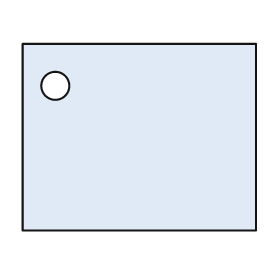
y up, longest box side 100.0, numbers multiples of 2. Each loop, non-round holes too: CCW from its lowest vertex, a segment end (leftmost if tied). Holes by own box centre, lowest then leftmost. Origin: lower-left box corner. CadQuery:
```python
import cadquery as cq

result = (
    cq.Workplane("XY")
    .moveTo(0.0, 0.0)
    .lineTo(100.0, 0.0)
    .lineTo(100.0, 80.0)
    .lineTo(0.0, 80.0)
    .close()
    .moveTo(14.0, 62.0)
    .circle(6.0)
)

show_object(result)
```